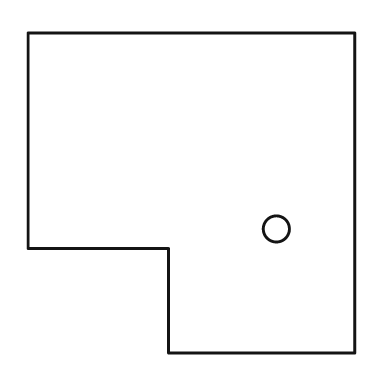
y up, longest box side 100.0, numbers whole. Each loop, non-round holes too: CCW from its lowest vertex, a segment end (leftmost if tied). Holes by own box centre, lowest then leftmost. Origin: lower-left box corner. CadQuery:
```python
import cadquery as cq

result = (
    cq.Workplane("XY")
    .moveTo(43.0, 0.0)
    .lineTo(100.0, 0.0)
    .lineTo(100.0, 98.0)
    .lineTo(0.0, 98.0)
    .lineTo(0.0, 32.0)
    .lineTo(43.0, 32.0)
    .close()
    .moveTo(76.0, 38.0)
    .circle(4.0)
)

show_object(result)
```